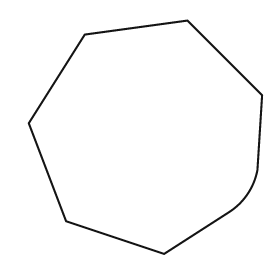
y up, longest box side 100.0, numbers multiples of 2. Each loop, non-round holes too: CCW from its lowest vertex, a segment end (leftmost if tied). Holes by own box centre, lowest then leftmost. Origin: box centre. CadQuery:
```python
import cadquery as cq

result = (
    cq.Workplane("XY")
    .moveTo(8.0, -50.0)
    .lineTo(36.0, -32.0)
    .threePointArc((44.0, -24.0), (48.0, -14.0))
    .lineTo(50.0, 18.0)
    .lineTo(18.0, 50.0)
    .lineTo(-26.0, 44.0)
    .lineTo(-50.0, 6.0)
    .lineTo(-34.0, -36.0)
    .close()
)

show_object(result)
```